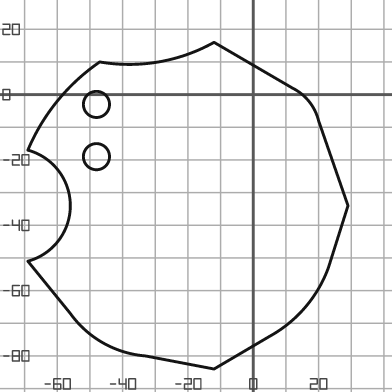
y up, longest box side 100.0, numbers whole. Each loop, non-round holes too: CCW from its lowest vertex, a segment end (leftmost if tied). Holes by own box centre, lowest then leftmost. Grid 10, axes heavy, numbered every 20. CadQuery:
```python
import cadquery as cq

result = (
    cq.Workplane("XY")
    .moveTo(-12.0, -84.0)
    .lineTo(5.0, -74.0)
    .threePointArc((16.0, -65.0), (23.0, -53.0))
    .lineTo(29.0, -34.0)
    .lineTo(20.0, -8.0)
    .threePointArc((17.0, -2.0), (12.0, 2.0))
    .lineTo(-12.0, 16.0)
    .threePointArc((-29.0, 10.0), (-47.0, 10.0))
    .threePointArc((-60.0, -2.0), (-69.0, -17.0))
    .threePointArc((-56.0, -34.0), (-69.0, -51.0))
    .lineTo(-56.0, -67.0)
    .threePointArc((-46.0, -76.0), (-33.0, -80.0))
    .close()
    .moveTo(-48.0, -19.0)
    .circle(4.0)
    .moveTo(-48.0, -3.0)
    .circle(4.0)
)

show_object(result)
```